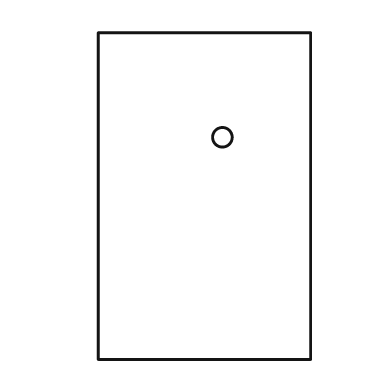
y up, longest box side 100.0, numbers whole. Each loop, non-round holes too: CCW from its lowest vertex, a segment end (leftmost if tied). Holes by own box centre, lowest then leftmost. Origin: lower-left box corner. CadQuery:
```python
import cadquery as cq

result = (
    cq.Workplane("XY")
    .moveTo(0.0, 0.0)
    .lineTo(65.0, 0.0)
    .lineTo(65.0, 100.0)
    .lineTo(0.0, 100.0)
    .close()
    .moveTo(38.0, 68.0)
    .circle(3.0)
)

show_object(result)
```